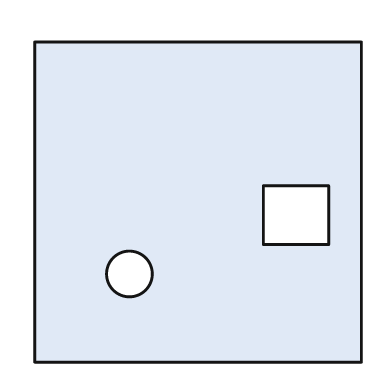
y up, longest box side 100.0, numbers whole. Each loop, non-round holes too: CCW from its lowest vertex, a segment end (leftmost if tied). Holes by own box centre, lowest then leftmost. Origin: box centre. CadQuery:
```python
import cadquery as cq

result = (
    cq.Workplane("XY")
    .moveTo(-50.0, -49.0)
    .lineTo(50.0, -49.0)
    .lineTo(50.0, 49.0)
    .lineTo(-50.0, 49.0)
    .close()
    .moveTo(-21.0, -22.0)
    .circle(7.0)
    .moveTo(20.0, -13.0)
    .lineTo(40.0, -13.0)
    .lineTo(40.0, 5.0)
    .lineTo(20.0, 5.0)
    .close()
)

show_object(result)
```